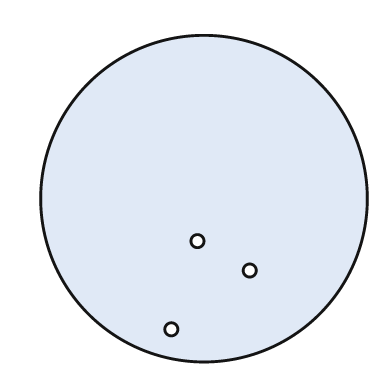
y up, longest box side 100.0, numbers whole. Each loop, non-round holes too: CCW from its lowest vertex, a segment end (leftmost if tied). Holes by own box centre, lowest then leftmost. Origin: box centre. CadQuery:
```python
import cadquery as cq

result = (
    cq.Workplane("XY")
    .moveTo(0.0, 0.0)
    .circle(50.0)
    .moveTo(-10.0, -40.0)
    .circle(2.0)
    .moveTo(14.0, -22.0)
    .circle(2.0)
    .moveTo(-2.0, -13.0)
    .circle(2.0)
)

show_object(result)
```